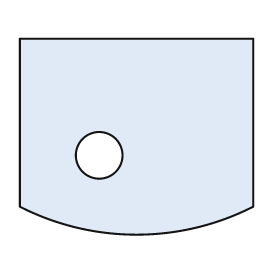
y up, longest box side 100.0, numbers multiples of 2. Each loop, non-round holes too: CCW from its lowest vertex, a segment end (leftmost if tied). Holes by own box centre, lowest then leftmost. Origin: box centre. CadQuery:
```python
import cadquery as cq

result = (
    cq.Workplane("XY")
    .moveTo(-50.0, -30.0)
    .threePointArc((0.0, -42.0), (50.0, -30.0))
    .lineTo(50.0, 42.0)
    .lineTo(-50.0, 42.0)
    .close()
    .moveTo(-16.0, -8.0)
    .circle(10.0)
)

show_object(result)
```